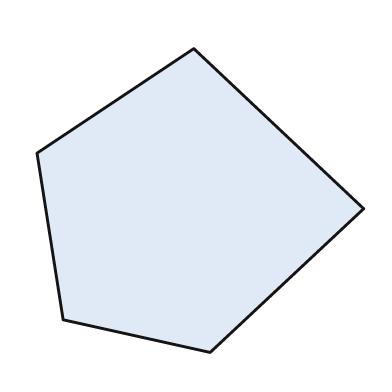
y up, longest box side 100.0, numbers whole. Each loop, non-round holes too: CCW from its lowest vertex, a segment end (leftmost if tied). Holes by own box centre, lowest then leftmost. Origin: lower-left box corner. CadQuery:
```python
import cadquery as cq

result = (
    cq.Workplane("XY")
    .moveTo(53.0, 0.0)
    .lineTo(100.0, 44.0)
    .lineTo(48.0, 93.0)
    .lineTo(0.0, 61.0)
    .lineTo(8.0, 10.0)
    .close()
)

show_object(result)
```